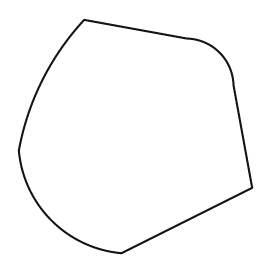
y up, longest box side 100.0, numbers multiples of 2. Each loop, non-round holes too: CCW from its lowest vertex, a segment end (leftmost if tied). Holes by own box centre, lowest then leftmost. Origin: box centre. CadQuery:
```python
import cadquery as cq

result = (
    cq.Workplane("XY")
    .moveTo(-6.0, -50.0)
    .lineTo(50.0, -22.0)
    .lineTo(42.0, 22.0)
    .threePointArc((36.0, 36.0), (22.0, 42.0))
    .lineTo(-22.0, 50.0)
    .threePointArc((-40.0, 24.0), (-50.0, -6.0))
    .threePointArc((-36.0, -36.0), (-6.0, -50.0))
    .close()
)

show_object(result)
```